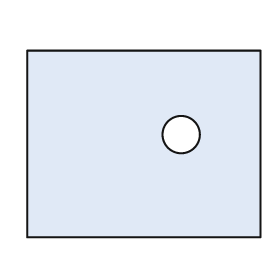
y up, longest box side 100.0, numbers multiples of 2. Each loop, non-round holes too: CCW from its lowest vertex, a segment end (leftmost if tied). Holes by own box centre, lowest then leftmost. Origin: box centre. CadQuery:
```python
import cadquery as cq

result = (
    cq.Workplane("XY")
    .moveTo(-50.0, -40.0)
    .lineTo(50.0, -40.0)
    .lineTo(50.0, 40.0)
    .lineTo(-50.0, 40.0)
    .close()
    .moveTo(16.0, 4.0)
    .circle(8.0)
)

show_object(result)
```